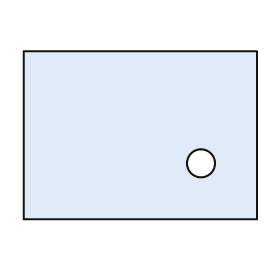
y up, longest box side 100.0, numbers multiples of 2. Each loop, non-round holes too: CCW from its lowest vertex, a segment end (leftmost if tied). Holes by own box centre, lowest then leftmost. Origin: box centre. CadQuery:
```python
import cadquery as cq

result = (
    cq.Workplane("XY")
    .moveTo(-50.0, -36.0)
    .lineTo(50.0, -36.0)
    .lineTo(50.0, 36.0)
    .lineTo(-50.0, 36.0)
    .close()
    .moveTo(26.0, -12.0)
    .circle(6.0)
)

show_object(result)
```